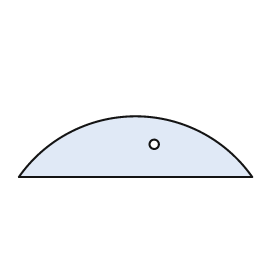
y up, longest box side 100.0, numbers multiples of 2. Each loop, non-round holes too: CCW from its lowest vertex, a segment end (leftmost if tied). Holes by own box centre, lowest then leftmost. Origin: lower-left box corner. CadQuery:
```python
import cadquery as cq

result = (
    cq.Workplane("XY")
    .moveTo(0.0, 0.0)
    .lineTo(100.0, 0.0)
    .threePointArc((50.0, 26.0), (0.0, 0.0))
    .close()
    .moveTo(58.0, 14.0)
    .circle(2.0)
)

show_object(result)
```